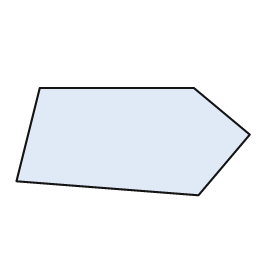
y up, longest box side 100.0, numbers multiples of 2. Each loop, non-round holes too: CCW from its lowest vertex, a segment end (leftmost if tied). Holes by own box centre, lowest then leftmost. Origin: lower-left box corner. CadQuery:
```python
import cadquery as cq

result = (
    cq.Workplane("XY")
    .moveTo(78.0, 0.0)
    .lineTo(100.0, 26.0)
    .lineTo(76.0, 46.0)
    .lineTo(10.0, 46.0)
    .lineTo(0.0, 6.0)
    .close()
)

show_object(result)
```